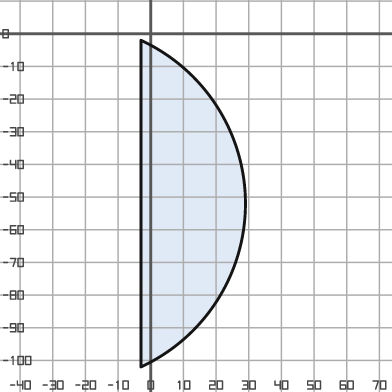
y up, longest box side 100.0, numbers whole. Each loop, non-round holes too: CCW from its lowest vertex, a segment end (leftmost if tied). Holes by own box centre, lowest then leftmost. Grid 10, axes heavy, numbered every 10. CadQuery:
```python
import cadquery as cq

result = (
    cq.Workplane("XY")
    .moveTo(-3.0, -102.0)
    .threePointArc((29.0, -52.0), (-3.0, -2.0))
    .close()
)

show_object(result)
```